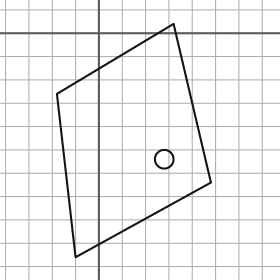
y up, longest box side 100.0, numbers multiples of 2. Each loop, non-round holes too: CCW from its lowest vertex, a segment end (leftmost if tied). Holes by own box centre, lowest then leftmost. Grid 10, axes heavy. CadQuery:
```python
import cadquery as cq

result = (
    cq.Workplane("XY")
    .moveTo(-10.0, -96.0)
    .lineTo(48.0, -64.0)
    .lineTo(32.0, 4.0)
    .lineTo(-18.0, -26.0)
    .close()
    .moveTo(28.0, -54.0)
    .circle(4.0)
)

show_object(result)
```